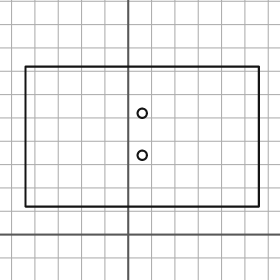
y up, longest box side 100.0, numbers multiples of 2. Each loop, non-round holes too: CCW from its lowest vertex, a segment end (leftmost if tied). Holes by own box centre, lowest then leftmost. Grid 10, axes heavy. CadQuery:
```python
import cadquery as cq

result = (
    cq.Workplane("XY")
    .moveTo(-44.0, 12.0)
    .lineTo(56.0, 12.0)
    .lineTo(56.0, 72.0)
    .lineTo(-44.0, 72.0)
    .close()
    .moveTo(6.0, 34.0)
    .circle(2.0)
    .moveTo(6.0, 52.0)
    .circle(2.0)
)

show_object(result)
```